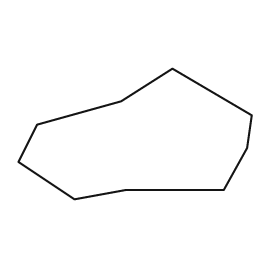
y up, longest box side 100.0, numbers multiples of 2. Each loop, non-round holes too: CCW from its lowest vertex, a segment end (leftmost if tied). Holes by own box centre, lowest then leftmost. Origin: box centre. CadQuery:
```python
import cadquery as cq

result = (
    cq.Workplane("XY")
    .moveTo(-26.0, -28.0)
    .lineTo(-4.0, -24.0)
    .lineTo(38.0, -24.0)
    .lineTo(48.0, -6.0)
    .lineTo(50.0, 8.0)
    .lineTo(16.0, 28.0)
    .lineTo(-6.0, 14.0)
    .lineTo(-42.0, 4.0)
    .lineTo(-50.0, -12.0)
    .close()
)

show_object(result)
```